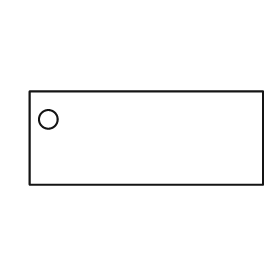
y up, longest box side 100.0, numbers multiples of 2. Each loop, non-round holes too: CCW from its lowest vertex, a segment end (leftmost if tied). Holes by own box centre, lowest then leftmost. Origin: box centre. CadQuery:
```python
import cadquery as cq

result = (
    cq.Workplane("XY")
    .moveTo(-50.0, -20.0)
    .lineTo(50.0, -20.0)
    .lineTo(50.0, 20.0)
    .lineTo(-50.0, 20.0)
    .close()
    .moveTo(-42.0, 8.0)
    .circle(4.0)
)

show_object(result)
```